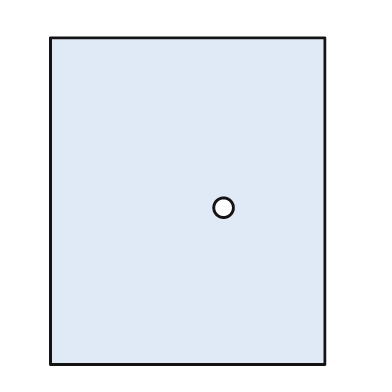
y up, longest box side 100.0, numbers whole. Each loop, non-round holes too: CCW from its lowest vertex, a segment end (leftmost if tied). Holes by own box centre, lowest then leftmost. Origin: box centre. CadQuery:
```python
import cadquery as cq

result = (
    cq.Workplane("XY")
    .moveTo(-42.0, -50.0)
    .lineTo(42.0, -50.0)
    .lineTo(42.0, 50.0)
    .lineTo(-42.0, 50.0)
    .close()
    .moveTo(11.0, -2.0)
    .circle(3.0)
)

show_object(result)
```